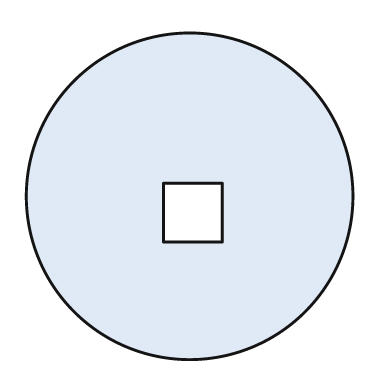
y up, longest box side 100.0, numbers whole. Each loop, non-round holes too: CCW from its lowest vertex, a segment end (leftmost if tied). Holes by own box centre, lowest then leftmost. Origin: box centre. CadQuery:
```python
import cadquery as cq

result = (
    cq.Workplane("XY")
    .moveTo(0.0, 0.0)
    .circle(50.0)
    .moveTo(-8.0, -14.0)
    .lineTo(10.0, -14.0)
    .lineTo(10.0, 4.0)
    .lineTo(-8.0, 4.0)
    .close()
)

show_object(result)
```